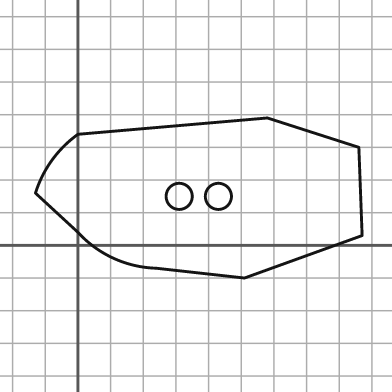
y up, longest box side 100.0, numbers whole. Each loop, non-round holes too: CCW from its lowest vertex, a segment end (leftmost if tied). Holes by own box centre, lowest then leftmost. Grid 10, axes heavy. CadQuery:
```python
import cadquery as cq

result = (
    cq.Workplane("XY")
    .moveTo(51.0, -10.0)
    .lineTo(87.0, 3.0)
    .lineTo(86.0, 30.0)
    .lineTo(58.0, 39.0)
    .lineTo(0.0, 34.0)
    .threePointArc((-8.0, 26.0), (-13.0, 16.0))
    .lineTo(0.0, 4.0)
    .threePointArc((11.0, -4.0), (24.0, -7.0))
    .close()
    .moveTo(31.0, 15.0)
    .circle(4.0)
    .moveTo(43.0, 15.0)
    .circle(4.0)
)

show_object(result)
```